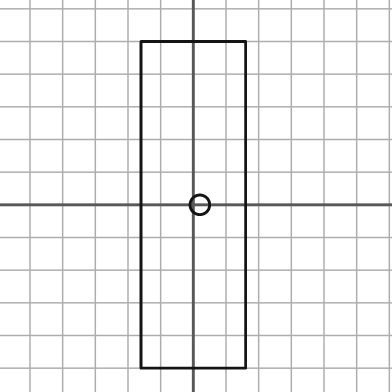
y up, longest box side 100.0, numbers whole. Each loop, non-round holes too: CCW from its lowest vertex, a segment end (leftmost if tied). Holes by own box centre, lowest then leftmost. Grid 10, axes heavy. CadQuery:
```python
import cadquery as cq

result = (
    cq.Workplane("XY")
    .moveTo(-16.0, -50.0)
    .lineTo(16.0, -50.0)
    .lineTo(16.0, 50.0)
    .lineTo(-16.0, 50.0)
    .close()
    .moveTo(2.0, 0.0)
    .circle(3.0)
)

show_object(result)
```